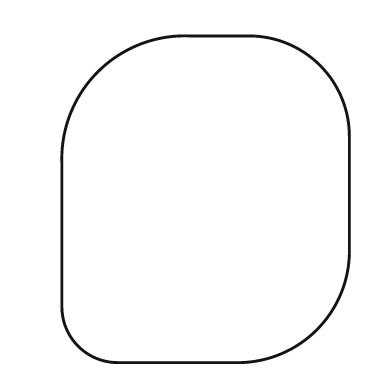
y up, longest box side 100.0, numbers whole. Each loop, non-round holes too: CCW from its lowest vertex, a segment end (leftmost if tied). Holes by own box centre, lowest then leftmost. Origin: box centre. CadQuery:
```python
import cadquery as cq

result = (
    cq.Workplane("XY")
    .moveTo(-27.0, -50.0)
    .lineTo(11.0, -50.0)
    .threePointArc((34.0, -40.0), (44.0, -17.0))
    .lineTo(44.0, 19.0)
    .threePointArc((35.0, 41.0), (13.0, 50.0))
    .lineTo(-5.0, 50.0)
    .threePointArc((-33.0, 39.0), (-44.0, 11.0))
    .lineTo(-44.0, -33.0)
    .threePointArc((-39.0, -45.0), (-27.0, -50.0))
    .close()
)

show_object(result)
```